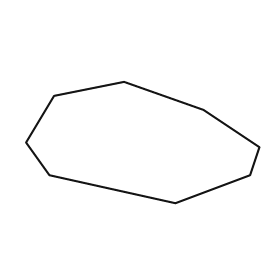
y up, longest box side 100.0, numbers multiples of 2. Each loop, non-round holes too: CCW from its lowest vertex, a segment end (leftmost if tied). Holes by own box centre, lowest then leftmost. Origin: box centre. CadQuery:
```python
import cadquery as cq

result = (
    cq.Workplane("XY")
    .moveTo(14.0, -26.0)
    .lineTo(46.0, -14.0)
    .lineTo(50.0, -2.0)
    .lineTo(26.0, 14.0)
    .lineTo(-8.0, 26.0)
    .lineTo(-38.0, 20.0)
    .lineTo(-50.0, 0.0)
    .lineTo(-40.0, -14.0)
    .close()
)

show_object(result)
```